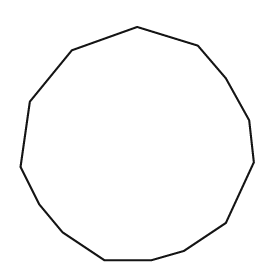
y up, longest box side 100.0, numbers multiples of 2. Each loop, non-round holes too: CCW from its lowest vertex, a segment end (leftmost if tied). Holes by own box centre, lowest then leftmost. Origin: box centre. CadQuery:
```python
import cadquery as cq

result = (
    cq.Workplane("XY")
    .moveTo(-14.0, -50.0)
    .lineTo(6.0, -50.0)
    .lineTo(20.0, -46.0)
    .lineTo(38.0, -34.0)
    .lineTo(50.0, -8.0)
    .lineTo(48.0, 10.0)
    .lineTo(38.0, 28.0)
    .lineTo(26.0, 42.0)
    .lineTo(0.0, 50.0)
    .lineTo(-28.0, 40.0)
    .lineTo(-46.0, 18.0)
    .lineTo(-50.0, -10.0)
    .lineTo(-42.0, -26.0)
    .lineTo(-32.0, -38.0)
    .close()
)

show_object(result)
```